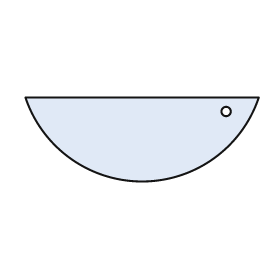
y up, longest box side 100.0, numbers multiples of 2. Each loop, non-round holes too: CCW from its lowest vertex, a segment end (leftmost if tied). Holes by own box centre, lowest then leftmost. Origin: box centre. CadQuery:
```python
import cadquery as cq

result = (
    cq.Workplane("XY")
    .moveTo(-50.0, 18.0)
    .threePointArc((0.0, -18.0), (50.0, 18.0))
    .close()
    .moveTo(36.0, 12.0)
    .circle(2.0)
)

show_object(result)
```